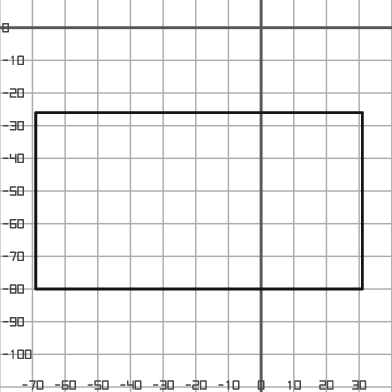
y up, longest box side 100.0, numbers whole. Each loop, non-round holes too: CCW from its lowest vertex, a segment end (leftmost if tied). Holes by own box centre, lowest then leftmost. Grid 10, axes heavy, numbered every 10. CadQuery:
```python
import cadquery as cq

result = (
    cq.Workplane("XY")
    .moveTo(-69.0, -80.0)
    .lineTo(31.0, -80.0)
    .lineTo(31.0, -26.0)
    .lineTo(-69.0, -26.0)
    .close()
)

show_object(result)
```